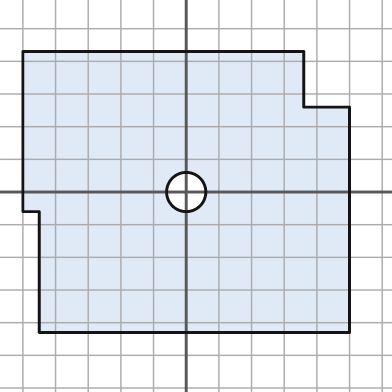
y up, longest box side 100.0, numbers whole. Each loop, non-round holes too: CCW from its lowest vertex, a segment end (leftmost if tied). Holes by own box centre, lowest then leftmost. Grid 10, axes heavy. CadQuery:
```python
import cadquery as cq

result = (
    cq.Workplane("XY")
    .moveTo(-45.0, -43.0)
    .lineTo(50.0, -43.0)
    .lineTo(50.0, 26.0)
    .lineTo(36.0, 26.0)
    .lineTo(36.0, 43.0)
    .lineTo(-50.0, 43.0)
    .lineTo(-50.0, -6.0)
    .lineTo(-45.0, -6.0)
    .close()
    .moveTo(0.0, 0.0)
    .circle(6.0)
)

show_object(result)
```